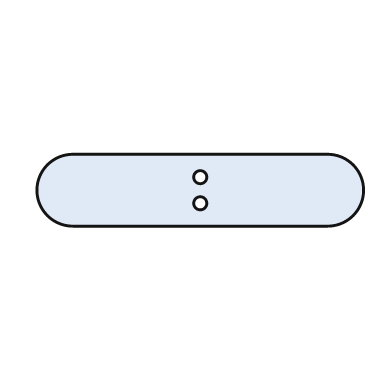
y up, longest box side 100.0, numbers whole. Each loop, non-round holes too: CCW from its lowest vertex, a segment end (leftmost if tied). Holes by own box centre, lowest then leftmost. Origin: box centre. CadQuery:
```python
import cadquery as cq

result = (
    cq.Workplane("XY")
    .moveTo(-39.0, -11.0)
    .lineTo(39.0, -11.0)
    .threePointArc((50.0, 0.0), (39.0, 11.0))
    .lineTo(-39.0, 11.0)
    .threePointArc((-50.0, 0.0), (-39.0, -11.0))
    .close()
    .moveTo(0.0, -4.0)
    .circle(2.0)
    .moveTo(0.0, 4.0)
    .circle(2.0)
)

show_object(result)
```